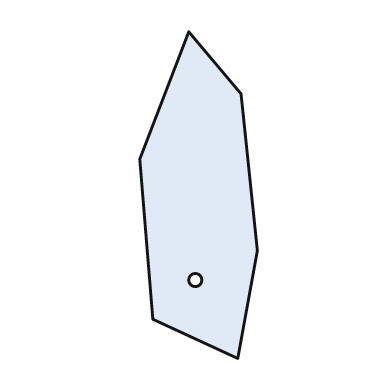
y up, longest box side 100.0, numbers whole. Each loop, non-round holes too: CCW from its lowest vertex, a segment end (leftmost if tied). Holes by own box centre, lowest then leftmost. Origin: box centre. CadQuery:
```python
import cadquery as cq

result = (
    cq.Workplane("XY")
    .moveTo(12.0, -50.0)
    .lineTo(18.0, -17.0)
    .lineTo(13.0, 31.0)
    .lineTo(-3.0, 50.0)
    .lineTo(-18.0, 11.0)
    .lineTo(-14.0, -38.0)
    .close()
    .moveTo(-1.0, -26.0)
    .circle(2.0)
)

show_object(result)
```